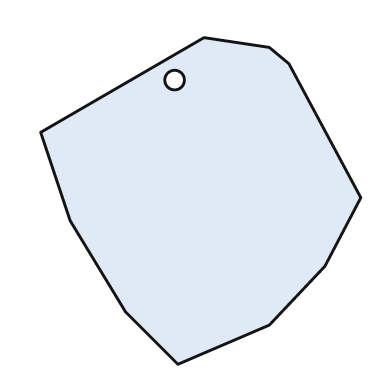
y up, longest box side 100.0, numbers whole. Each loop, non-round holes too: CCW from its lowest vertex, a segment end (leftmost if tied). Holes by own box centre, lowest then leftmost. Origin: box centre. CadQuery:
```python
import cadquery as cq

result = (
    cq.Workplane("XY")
    .moveTo(-7.0, -50.0)
    .lineTo(21.0, -38.0)
    .lineTo(38.0, -20.0)
    .lineTo(49.0, 1.0)
    .lineTo(27.0, 42.0)
    .lineTo(21.0, 47.0)
    .lineTo(1.0, 50.0)
    .lineTo(-49.0, 21.0)
    .lineTo(-40.0, -6.0)
    .lineTo(-23.0, -34.0)
    .close()
    .moveTo(-8.0, 37.0)
    .circle(3.0)
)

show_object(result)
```